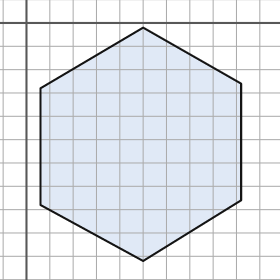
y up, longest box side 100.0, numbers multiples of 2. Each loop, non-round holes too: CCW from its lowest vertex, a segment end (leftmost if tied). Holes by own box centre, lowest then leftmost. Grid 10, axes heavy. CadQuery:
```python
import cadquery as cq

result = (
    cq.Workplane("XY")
    .moveTo(50.0, -102.0)
    .lineTo(92.0, -76.0)
    .lineTo(92.0, -26.0)
    .lineTo(50.0, -2.0)
    .lineTo(6.0, -28.0)
    .lineTo(6.0, -78.0)
    .close()
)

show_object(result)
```